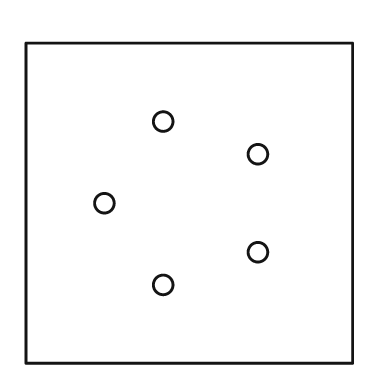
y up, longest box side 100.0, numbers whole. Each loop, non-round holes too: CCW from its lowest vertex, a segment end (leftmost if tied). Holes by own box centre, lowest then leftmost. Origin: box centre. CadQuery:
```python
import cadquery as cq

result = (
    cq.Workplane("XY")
    .moveTo(-50.0, -49.0)
    .lineTo(50.0, -49.0)
    .lineTo(50.0, 49.0)
    .lineTo(-50.0, 49.0)
    .close()
    .moveTo(-8.0, -25.0)
    .circle(3.0)
    .moveTo(21.0, -15.0)
    .circle(3.0)
    .moveTo(-26.0, 0.0)
    .circle(3.0)
    .moveTo(21.0, 15.0)
    .circle(3.0)
    .moveTo(-8.0, 25.0)
    .circle(3.0)
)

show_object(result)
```